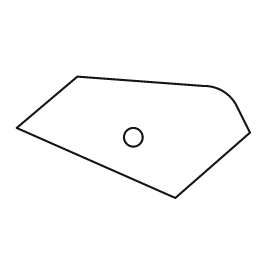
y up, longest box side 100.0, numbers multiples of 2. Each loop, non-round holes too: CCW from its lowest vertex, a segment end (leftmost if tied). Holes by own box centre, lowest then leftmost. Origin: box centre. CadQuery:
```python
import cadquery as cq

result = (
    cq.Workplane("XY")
    .moveTo(18.0, -26.0)
    .lineTo(50.0, 2.0)
    .lineTo(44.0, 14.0)
    .threePointArc((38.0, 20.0), (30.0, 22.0))
    .lineTo(-24.0, 26.0)
    .lineTo(-50.0, 4.0)
    .close()
    .moveTo(0.0, 0.0)
    .circle(4.0)
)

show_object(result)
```